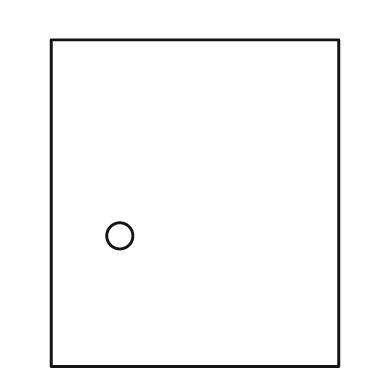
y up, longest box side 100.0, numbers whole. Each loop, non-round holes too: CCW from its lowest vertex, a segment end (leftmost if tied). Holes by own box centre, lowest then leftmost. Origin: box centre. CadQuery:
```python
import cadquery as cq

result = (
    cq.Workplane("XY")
    .moveTo(-44.0, -50.0)
    .lineTo(44.0, -50.0)
    .lineTo(44.0, 50.0)
    .lineTo(-44.0, 50.0)
    .close()
    .moveTo(-23.0, -10.0)
    .circle(4.0)
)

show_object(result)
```